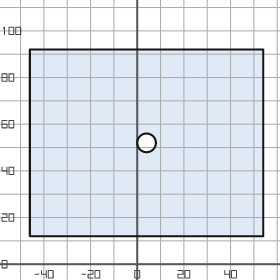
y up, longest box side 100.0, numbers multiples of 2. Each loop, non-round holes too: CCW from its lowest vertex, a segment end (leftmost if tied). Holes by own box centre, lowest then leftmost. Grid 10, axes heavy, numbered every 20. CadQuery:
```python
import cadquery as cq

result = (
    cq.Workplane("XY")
    .moveTo(-46.0, 12.0)
    .lineTo(54.0, 12.0)
    .lineTo(54.0, 92.0)
    .lineTo(-46.0, 92.0)
    .close()
    .moveTo(4.0, 52.0)
    .circle(4.0)
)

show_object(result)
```